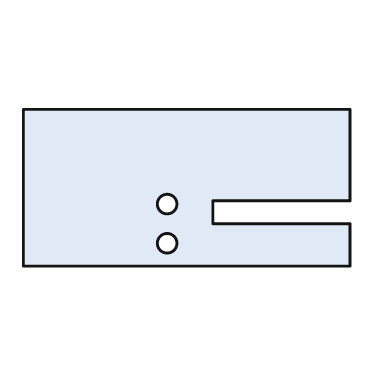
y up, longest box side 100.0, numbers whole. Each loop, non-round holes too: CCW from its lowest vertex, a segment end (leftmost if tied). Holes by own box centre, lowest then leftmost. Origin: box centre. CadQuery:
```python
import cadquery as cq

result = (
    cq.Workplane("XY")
    .moveTo(-50.0, -24.0)
    .lineTo(50.0, -24.0)
    .lineTo(50.0, -11.0)
    .lineTo(8.0, -11.0)
    .lineTo(8.0, -4.0)
    .lineTo(50.0, -4.0)
    .lineTo(50.0, 24.0)
    .lineTo(-50.0, 24.0)
    .close()
    .moveTo(-6.0, -17.0)
    .circle(3.0)
    .moveTo(-6.0, -5.0)
    .circle(3.0)
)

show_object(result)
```